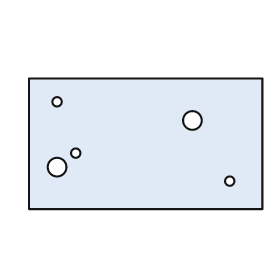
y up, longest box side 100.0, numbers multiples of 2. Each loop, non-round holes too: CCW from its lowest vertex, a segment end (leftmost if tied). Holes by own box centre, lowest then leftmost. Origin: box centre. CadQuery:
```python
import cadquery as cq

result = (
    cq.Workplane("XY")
    .moveTo(-50.0, -28.0)
    .lineTo(50.0, -28.0)
    .lineTo(50.0, 28.0)
    .lineTo(-50.0, 28.0)
    .close()
    .moveTo(36.0, -16.0)
    .circle(2.0)
    .moveTo(-38.0, -10.0)
    .circle(4.0)
    .moveTo(-30.0, -4.0)
    .circle(2.0)
    .moveTo(20.0, 10.0)
    .circle(4.0)
    .moveTo(-38.0, 18.0)
    .circle(2.0)
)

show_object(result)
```